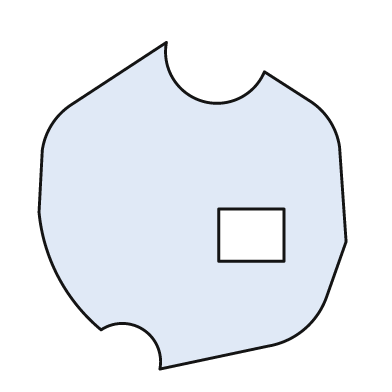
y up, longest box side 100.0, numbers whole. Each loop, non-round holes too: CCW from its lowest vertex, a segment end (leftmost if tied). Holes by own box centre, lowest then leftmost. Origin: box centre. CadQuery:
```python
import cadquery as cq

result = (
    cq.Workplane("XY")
    .moveTo(-10.0, -50.0)
    .lineTo(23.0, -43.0)
    .threePointArc((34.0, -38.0), (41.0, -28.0))
    .lineTo(47.0, -11.0)
    .lineTo(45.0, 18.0)
    .threePointArc((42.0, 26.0), (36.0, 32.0))
    .lineTo(22.0, 41.0)
    .threePointArc((3.0, 32.0), (-8.0, 50.0))
    .lineTo(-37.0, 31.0)
    .threePointArc((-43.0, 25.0), (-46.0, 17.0))
    .lineTo(-47.0, -2.0)
    .threePointArc((-41.0, -22.0), (-28.0, -38.0))
    .threePointArc((-15.0, -38.0), (-10.0, -50.0))
    .close()
    .moveTo(8.0, -17.0)
    .lineTo(28.0, -17.0)
    .lineTo(28.0, -1.0)
    .lineTo(8.0, -1.0)
    .close()
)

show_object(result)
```